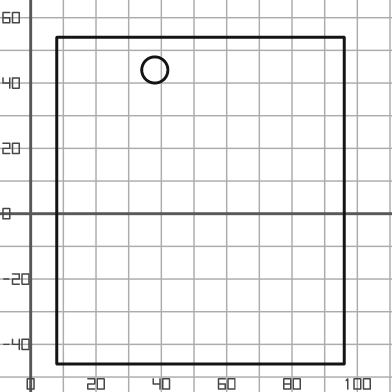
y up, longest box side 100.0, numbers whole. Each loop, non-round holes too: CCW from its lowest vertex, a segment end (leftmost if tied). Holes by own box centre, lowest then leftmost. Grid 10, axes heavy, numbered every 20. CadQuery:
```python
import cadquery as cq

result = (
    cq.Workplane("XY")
    .moveTo(8.0, -46.0)
    .lineTo(96.0, -46.0)
    .lineTo(96.0, 54.0)
    .lineTo(8.0, 54.0)
    .close()
    .moveTo(38.0, 44.0)
    .circle(4.0)
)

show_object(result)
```